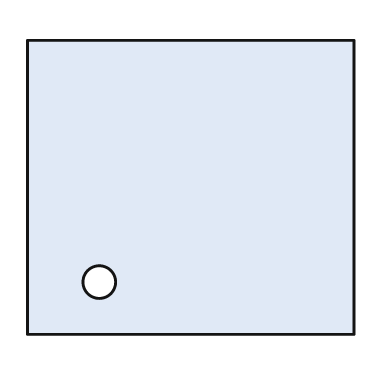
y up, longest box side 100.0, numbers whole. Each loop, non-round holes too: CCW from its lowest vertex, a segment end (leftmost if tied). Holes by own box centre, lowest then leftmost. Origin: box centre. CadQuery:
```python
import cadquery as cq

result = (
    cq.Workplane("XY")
    .moveTo(-50.0, -45.0)
    .lineTo(50.0, -45.0)
    .lineTo(50.0, 45.0)
    .lineTo(-50.0, 45.0)
    .close()
    .moveTo(-28.0, -29.0)
    .circle(5.0)
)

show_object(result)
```